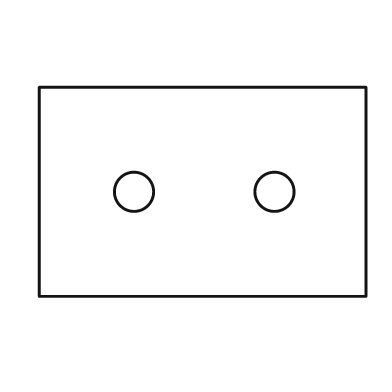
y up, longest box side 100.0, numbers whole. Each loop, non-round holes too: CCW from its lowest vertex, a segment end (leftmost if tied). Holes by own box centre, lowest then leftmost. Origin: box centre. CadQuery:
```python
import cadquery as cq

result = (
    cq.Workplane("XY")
    .moveTo(-50.0, -32.0)
    .lineTo(50.0, -32.0)
    .lineTo(50.0, 32.0)
    .lineTo(-50.0, 32.0)
    .close()
    .moveTo(-21.0, 0.0)
    .circle(6.0)
    .moveTo(22.0, 0.0)
    .circle(6.0)
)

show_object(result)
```